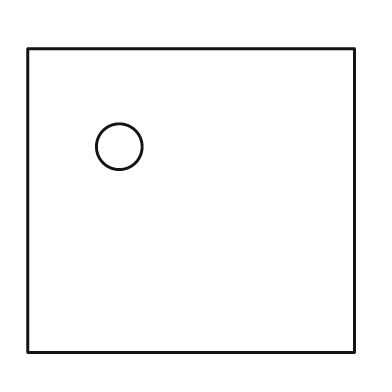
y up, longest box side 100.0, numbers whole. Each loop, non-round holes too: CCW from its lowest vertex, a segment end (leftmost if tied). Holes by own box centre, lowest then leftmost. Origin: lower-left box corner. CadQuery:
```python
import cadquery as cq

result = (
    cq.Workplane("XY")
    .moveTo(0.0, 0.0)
    .lineTo(100.0, 0.0)
    .lineTo(100.0, 93.0)
    .lineTo(0.0, 93.0)
    .close()
    .moveTo(28.0, 63.0)
    .circle(7.0)
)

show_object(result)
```